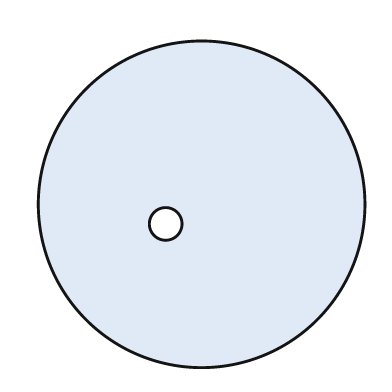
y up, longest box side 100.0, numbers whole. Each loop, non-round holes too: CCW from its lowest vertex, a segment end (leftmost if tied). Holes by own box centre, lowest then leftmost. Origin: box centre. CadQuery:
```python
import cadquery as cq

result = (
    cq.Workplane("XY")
    .moveTo(0.0, 0.0)
    .circle(50.0)
    .moveTo(-11.0, -6.0)
    .circle(5.0)
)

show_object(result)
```